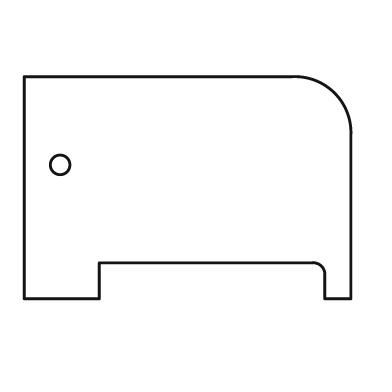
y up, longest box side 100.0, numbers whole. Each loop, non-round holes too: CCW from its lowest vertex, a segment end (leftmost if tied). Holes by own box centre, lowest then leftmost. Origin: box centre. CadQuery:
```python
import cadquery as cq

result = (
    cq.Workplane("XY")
    .moveTo(-50.0, -34.0)
    .lineTo(-27.0, -34.0)
    .lineTo(-27.0, -23.0)
    .lineTo(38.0, -23.0)
    .threePointArc((41.0, -24.0), (42.0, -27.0))
    .lineTo(42.0, -34.0)
    .lineTo(50.0, -34.0)
    .lineTo(50.0, 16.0)
    .threePointArc((45.0, 29.0), (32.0, 34.0))
    .lineTo(-50.0, 34.0)
    .close()
    .moveTo(-39.0, 7.0)
    .circle(3.0)
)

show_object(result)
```